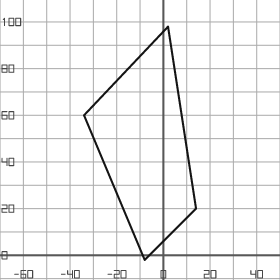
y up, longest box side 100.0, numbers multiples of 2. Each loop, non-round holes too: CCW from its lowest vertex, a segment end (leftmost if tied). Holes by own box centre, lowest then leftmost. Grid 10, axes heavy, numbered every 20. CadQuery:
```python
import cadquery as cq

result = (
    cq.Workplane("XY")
    .moveTo(-8.0, -2.0)
    .lineTo(14.0, 20.0)
    .lineTo(2.0, 98.0)
    .lineTo(-34.0, 60.0)
    .close()
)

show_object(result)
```